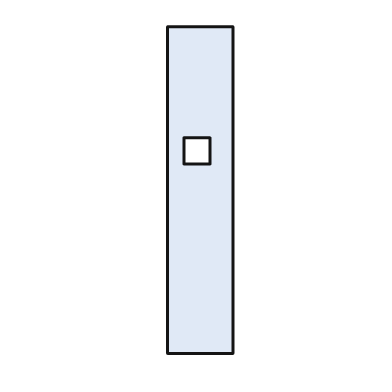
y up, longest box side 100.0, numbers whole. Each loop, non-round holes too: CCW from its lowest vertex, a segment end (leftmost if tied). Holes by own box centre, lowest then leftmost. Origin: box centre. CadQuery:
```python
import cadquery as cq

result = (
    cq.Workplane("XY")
    .moveTo(-10.0, -50.0)
    .lineTo(10.0, -50.0)
    .lineTo(10.0, 50.0)
    .lineTo(-10.0, 50.0)
    .close()
    .moveTo(-5.0, 8.0)
    .lineTo(3.0, 8.0)
    .lineTo(3.0, 16.0)
    .lineTo(-5.0, 16.0)
    .close()
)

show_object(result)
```